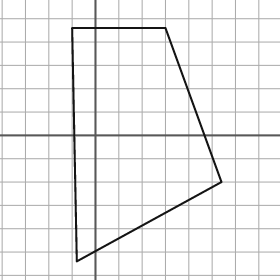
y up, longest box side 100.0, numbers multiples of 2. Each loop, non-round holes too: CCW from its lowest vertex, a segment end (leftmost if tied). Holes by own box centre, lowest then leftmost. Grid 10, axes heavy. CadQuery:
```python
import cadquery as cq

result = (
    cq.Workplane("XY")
    .moveTo(-8.0, -54.0)
    .lineTo(54.0, -20.0)
    .lineTo(30.0, 46.0)
    .lineTo(-10.0, 46.0)
    .close()
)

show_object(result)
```